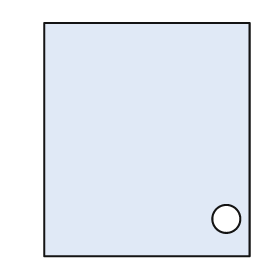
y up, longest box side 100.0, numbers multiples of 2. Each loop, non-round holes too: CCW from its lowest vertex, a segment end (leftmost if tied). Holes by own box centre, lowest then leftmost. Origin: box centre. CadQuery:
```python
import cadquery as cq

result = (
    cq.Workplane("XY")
    .moveTo(-44.0, -50.0)
    .lineTo(44.0, -50.0)
    .lineTo(44.0, 50.0)
    .lineTo(-44.0, 50.0)
    .close()
    .moveTo(34.0, -34.0)
    .circle(6.0)
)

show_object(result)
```